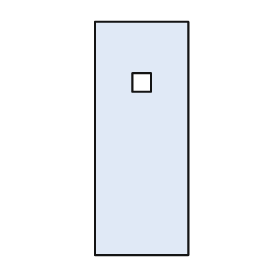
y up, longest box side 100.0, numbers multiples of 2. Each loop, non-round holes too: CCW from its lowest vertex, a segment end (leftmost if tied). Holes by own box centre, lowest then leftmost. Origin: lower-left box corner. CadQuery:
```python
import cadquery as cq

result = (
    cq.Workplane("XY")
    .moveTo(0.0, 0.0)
    .lineTo(40.0, 0.0)
    .lineTo(40.0, 100.0)
    .lineTo(0.0, 100.0)
    .close()
    .moveTo(16.0, 70.0)
    .lineTo(24.0, 70.0)
    .lineTo(24.0, 78.0)
    .lineTo(16.0, 78.0)
    .close()
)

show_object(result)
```